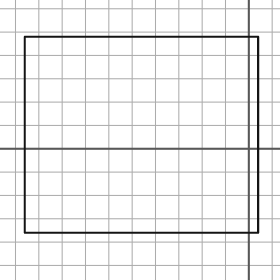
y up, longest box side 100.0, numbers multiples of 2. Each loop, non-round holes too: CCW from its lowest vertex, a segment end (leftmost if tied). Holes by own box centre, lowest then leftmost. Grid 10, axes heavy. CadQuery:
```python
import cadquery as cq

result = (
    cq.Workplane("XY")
    .moveTo(-96.0, -36.0)
    .lineTo(4.0, -36.0)
    .lineTo(4.0, 48.0)
    .lineTo(-96.0, 48.0)
    .close()
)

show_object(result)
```